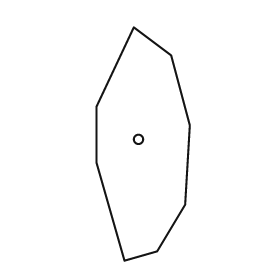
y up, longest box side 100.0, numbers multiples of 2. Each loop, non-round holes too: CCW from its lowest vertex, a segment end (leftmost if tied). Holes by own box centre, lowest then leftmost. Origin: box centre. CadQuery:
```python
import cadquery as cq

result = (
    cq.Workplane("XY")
    .moveTo(-8.0, -50.0)
    .lineTo(6.0, -46.0)
    .lineTo(18.0, -26.0)
    .lineTo(20.0, 8.0)
    .lineTo(12.0, 38.0)
    .lineTo(-4.0, 50.0)
    .lineTo(-20.0, 16.0)
    .lineTo(-20.0, -8.0)
    .close()
    .moveTo(-2.0, 2.0)
    .circle(2.0)
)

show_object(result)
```